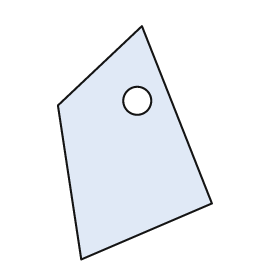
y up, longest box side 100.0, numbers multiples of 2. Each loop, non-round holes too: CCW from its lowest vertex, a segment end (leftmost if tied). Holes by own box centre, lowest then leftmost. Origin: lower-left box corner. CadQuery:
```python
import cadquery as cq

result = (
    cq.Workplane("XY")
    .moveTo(10.0, 0.0)
    .lineTo(66.0, 24.0)
    .lineTo(36.0, 100.0)
    .lineTo(0.0, 66.0)
    .close()
    .moveTo(34.0, 68.0)
    .circle(6.0)
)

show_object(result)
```